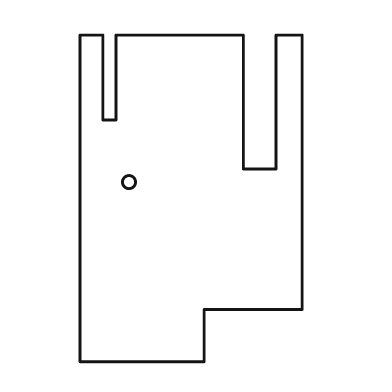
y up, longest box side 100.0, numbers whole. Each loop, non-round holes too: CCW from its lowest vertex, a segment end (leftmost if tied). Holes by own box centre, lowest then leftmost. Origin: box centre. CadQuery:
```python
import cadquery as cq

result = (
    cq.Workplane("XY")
    .moveTo(-34.0, -50.0)
    .lineTo(4.0, -50.0)
    .lineTo(4.0, -34.0)
    .lineTo(34.0, -34.0)
    .lineTo(34.0, 50.0)
    .lineTo(26.0, 50.0)
    .lineTo(26.0, 9.0)
    .lineTo(16.0, 9.0)
    .lineTo(16.0, 50.0)
    .lineTo(-23.0, 50.0)
    .lineTo(-23.0, 24.0)
    .lineTo(-27.0, 24.0)
    .lineTo(-27.0, 50.0)
    .lineTo(-34.0, 50.0)
    .close()
    .moveTo(-19.0, 5.0)
    .circle(2.0)
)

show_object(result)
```